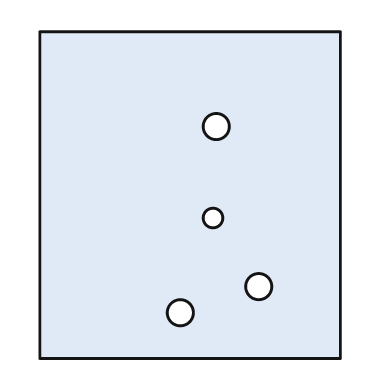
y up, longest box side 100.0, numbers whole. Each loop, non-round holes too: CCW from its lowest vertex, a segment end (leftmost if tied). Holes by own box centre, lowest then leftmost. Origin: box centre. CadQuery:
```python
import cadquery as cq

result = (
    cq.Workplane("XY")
    .moveTo(-46.0, -50.0)
    .lineTo(46.0, -50.0)
    .lineTo(46.0, 50.0)
    .lineTo(-46.0, 50.0)
    .close()
    .moveTo(-3.0, -36.0)
    .circle(4.0)
    .moveTo(21.0, -28.0)
    .circle(4.0)
    .moveTo(7.0, -7.0)
    .circle(3.0)
    .moveTo(8.0, 21.0)
    .circle(4.0)
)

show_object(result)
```